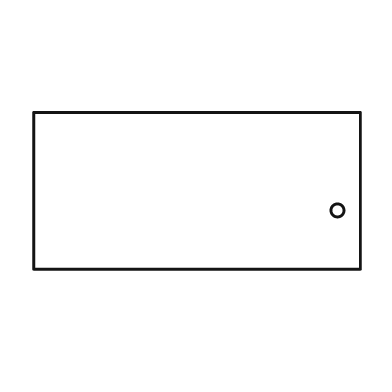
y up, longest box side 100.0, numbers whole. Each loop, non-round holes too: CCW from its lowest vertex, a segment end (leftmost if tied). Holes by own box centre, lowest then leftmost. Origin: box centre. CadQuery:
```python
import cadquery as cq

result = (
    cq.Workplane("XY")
    .moveTo(-50.0, -24.0)
    .lineTo(50.0, -24.0)
    .lineTo(50.0, 24.0)
    .lineTo(-50.0, 24.0)
    .close()
    .moveTo(43.0, -6.0)
    .circle(2.0)
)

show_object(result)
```